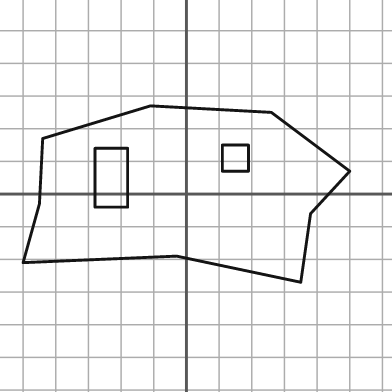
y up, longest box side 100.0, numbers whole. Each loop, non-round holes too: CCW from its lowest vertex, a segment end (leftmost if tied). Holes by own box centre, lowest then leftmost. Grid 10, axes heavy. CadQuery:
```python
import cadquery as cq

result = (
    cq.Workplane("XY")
    .moveTo(35.0, -27.0)
    .lineTo(38.0, -6.0)
    .lineTo(50.0, 7.0)
    .lineTo(26.0, 25.0)
    .lineTo(-11.0, 27.0)
    .lineTo(-44.0, 17.0)
    .lineTo(-45.0, -3.0)
    .lineTo(-50.0, -21.0)
    .lineTo(-3.0, -19.0)
    .close()
    .moveTo(-28.0, -4.0)
    .lineTo(-18.0, -4.0)
    .lineTo(-18.0, 14.0)
    .lineTo(-28.0, 14.0)
    .close()
    .moveTo(11.0, 7.0)
    .lineTo(19.0, 7.0)
    .lineTo(19.0, 15.0)
    .lineTo(11.0, 15.0)
    .close()
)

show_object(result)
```